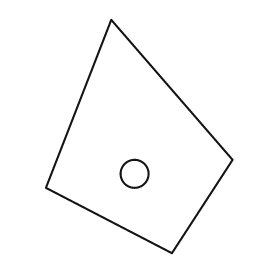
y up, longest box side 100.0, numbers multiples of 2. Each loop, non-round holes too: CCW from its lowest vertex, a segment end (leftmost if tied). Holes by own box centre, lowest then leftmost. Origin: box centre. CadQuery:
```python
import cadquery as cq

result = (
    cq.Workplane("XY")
    .moveTo(14.0, -50.0)
    .lineTo(40.0, -10.0)
    .lineTo(-12.0, 50.0)
    .lineTo(-40.0, -22.0)
    .close()
    .moveTo(-2.0, -16.0)
    .circle(6.0)
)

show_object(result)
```